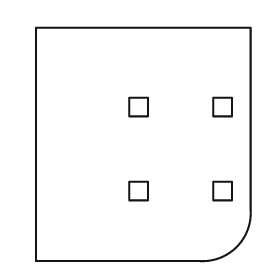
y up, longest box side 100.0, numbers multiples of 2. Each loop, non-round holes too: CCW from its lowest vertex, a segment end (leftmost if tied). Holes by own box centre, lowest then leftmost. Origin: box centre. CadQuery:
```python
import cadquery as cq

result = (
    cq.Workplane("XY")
    .moveTo(-46.0, -50.0)
    .lineTo(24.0, -50.0)
    .threePointArc((40.0, -44.0), (46.0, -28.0))
    .lineTo(46.0, 50.0)
    .lineTo(-46.0, 50.0)
    .close()
    .moveTo(-6.0, -24.0)
    .lineTo(2.0, -24.0)
    .lineTo(2.0, -16.0)
    .lineTo(-6.0, -16.0)
    .close()
    .moveTo(30.0, -24.0)
    .lineTo(38.0, -24.0)
    .lineTo(38.0, -16.0)
    .lineTo(30.0, -16.0)
    .close()
    .moveTo(-6.0, 12.0)
    .lineTo(2.0, 12.0)
    .lineTo(2.0, 20.0)
    .lineTo(-6.0, 20.0)
    .close()
    .moveTo(30.0, 12.0)
    .lineTo(38.0, 12.0)
    .lineTo(38.0, 20.0)
    .lineTo(30.0, 20.0)
    .close()
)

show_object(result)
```